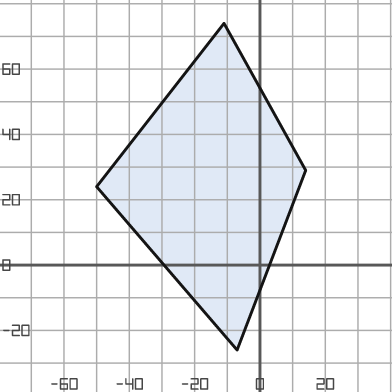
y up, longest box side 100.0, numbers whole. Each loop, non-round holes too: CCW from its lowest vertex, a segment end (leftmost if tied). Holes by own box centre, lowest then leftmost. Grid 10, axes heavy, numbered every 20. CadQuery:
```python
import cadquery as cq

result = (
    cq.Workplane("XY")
    .moveTo(-7.0, -26.0)
    .lineTo(14.0, 29.0)
    .lineTo(-11.0, 74.0)
    .lineTo(-50.0, 24.0)
    .close()
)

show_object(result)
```